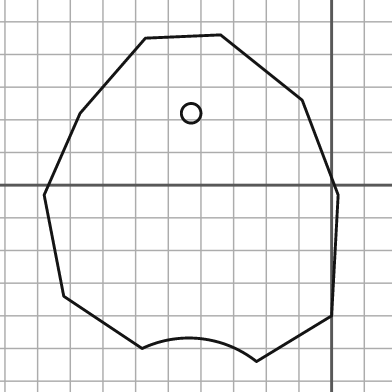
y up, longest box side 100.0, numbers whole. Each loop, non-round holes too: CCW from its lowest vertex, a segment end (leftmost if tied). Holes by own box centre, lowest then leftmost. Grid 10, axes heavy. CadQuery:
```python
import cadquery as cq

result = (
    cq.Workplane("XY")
    .moveTo(-23.0, -54.0)
    .lineTo(0.0, -40.0)
    .lineTo(2.0, -3.0)
    .lineTo(-9.0, 26.0)
    .lineTo(-34.0, 46.0)
    .lineTo(-57.0, 45.0)
    .lineTo(-77.0, 22.0)
    .lineTo(-88.0, -3.0)
    .lineTo(-82.0, -34.0)
    .lineTo(-58.0, -50.0)
    .threePointArc((-40.0, -47.0), (-23.0, -54.0))
    .close()
    .moveTo(-43.0, 22.0)
    .circle(3.0)
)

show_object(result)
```